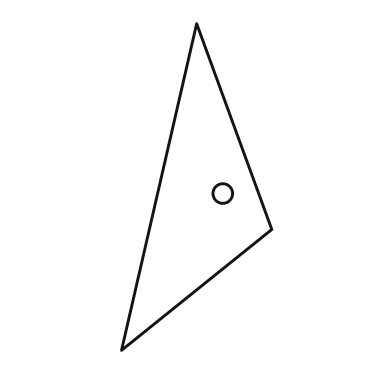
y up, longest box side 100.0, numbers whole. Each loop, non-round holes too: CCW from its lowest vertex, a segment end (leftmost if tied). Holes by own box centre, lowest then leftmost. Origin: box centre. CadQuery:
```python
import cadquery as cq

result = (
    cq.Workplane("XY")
    .moveTo(-23.0, -50.0)
    .lineTo(23.0, -13.0)
    .lineTo(0.0, 50.0)
    .close()
    .moveTo(8.0, -2.0)
    .circle(3.0)
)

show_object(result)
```